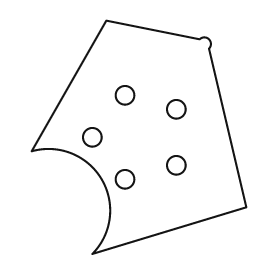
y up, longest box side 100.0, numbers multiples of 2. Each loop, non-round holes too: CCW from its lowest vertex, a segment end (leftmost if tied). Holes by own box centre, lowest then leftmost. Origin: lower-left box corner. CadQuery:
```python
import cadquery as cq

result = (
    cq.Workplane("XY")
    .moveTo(26.0, 0.0)
    .lineTo(92.0, 20.0)
    .lineTo(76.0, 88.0)
    .threePointArc((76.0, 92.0), (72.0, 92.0))
    .lineTo(32.0, 100.0)
    .lineTo(0.0, 44.0)
    .threePointArc((30.0, 32.0), (26.0, 0.0))
    .close()
    .moveTo(40.0, 32.0)
    .circle(4.0)
    .moveTo(62.0, 38.0)
    .circle(4.0)
    .moveTo(26.0, 50.0)
    .circle(4.0)
    .moveTo(62.0, 62.0)
    .circle(4.0)
    .moveTo(40.0, 68.0)
    .circle(4.0)
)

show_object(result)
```